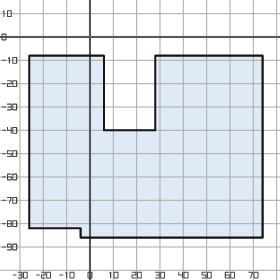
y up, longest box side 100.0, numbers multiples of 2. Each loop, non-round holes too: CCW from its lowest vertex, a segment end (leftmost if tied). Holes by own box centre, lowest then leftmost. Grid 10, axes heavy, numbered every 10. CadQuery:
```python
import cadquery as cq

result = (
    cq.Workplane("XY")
    .moveTo(-4.0, -86.0)
    .lineTo(74.0, -86.0)
    .lineTo(74.0, -8.0)
    .lineTo(28.0, -8.0)
    .lineTo(28.0, -40.0)
    .lineTo(6.0, -40.0)
    .lineTo(6.0, -8.0)
    .lineTo(-26.0, -8.0)
    .lineTo(-26.0, -82.0)
    .lineTo(-4.0, -82.0)
    .close()
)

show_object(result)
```